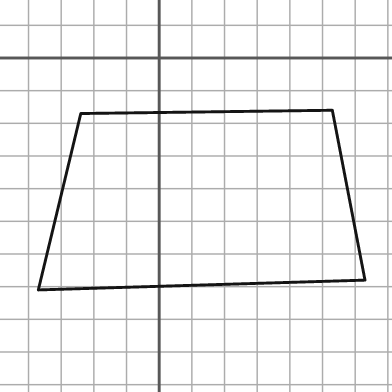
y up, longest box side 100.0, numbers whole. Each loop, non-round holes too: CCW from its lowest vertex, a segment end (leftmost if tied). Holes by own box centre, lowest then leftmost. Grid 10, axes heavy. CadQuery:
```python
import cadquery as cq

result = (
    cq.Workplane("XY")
    .moveTo(-37.0, -71.0)
    .lineTo(63.0, -68.0)
    .lineTo(53.0, -16.0)
    .lineTo(-24.0, -17.0)
    .close()
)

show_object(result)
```